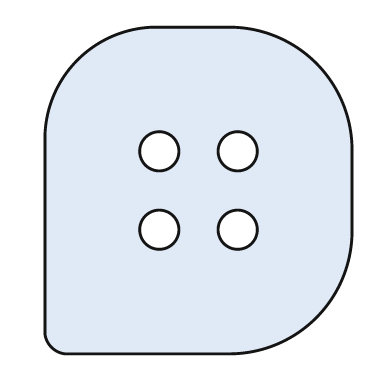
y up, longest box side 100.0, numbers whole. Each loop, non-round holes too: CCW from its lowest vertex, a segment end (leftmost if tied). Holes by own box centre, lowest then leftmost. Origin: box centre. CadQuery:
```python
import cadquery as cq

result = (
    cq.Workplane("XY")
    .moveTo(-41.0, -50.0)
    .lineTo(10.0, -50.0)
    .threePointArc((36.0, -39.0), (47.0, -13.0))
    .lineTo(47.0, 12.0)
    .threePointArc((36.0, 39.0), (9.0, 50.0))
    .lineTo(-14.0, 50.0)
    .threePointArc((-37.0, 40.0), (-47.0, 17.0))
    .lineTo(-47.0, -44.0)
    .threePointArc((-45.0, -48.0), (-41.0, -50.0))
    .close()
    .moveTo(-12.0, -12.0)
    .circle(6.0)
    .moveTo(12.0, -12.0)
    .circle(6.0)
    .moveTo(-12.0, 12.0)
    .circle(6.0)
    .moveTo(12.0, 12.0)
    .circle(6.0)
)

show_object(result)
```